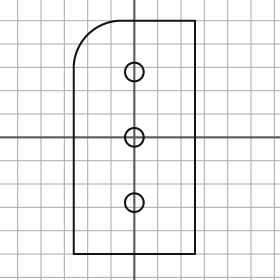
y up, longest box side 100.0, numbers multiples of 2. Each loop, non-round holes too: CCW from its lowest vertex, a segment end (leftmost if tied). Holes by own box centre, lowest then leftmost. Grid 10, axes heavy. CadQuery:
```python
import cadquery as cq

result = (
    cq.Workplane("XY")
    .moveTo(-26.0, -50.0)
    .lineTo(26.0, -50.0)
    .lineTo(26.0, 50.0)
    .lineTo(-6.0, 50.0)
    .threePointArc((-20.0, 44.0), (-26.0, 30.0))
    .close()
    .moveTo(0.0, -28.0)
    .circle(4.0)
    .moveTo(0.0, 0.0)
    .circle(4.0)
    .moveTo(0.0, 28.0)
    .circle(4.0)
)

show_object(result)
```